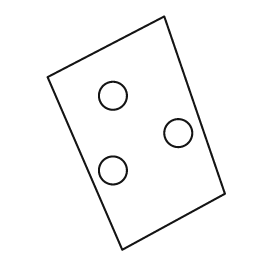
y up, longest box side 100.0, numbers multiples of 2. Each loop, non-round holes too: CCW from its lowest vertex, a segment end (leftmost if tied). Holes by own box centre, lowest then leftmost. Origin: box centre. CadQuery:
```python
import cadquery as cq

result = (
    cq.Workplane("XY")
    .moveTo(-6.0, -50.0)
    .lineTo(38.0, -26.0)
    .lineTo(12.0, 50.0)
    .lineTo(-38.0, 24.0)
    .close()
    .moveTo(-10.0, -16.0)
    .circle(6.0)
    .moveTo(18.0, 0.0)
    .circle(6.0)
    .moveTo(-10.0, 16.0)
    .circle(6.0)
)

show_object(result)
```